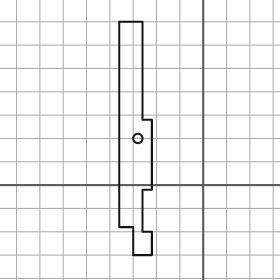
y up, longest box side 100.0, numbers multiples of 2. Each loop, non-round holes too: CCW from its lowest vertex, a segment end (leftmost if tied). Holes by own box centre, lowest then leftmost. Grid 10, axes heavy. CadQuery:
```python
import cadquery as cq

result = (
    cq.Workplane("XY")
    .moveTo(-30.0, -30.0)
    .lineTo(-22.0, -30.0)
    .lineTo(-22.0, -20.0)
    .lineTo(-26.0, -20.0)
    .lineTo(-26.0, -2.0)
    .lineTo(-22.0, -2.0)
    .lineTo(-22.0, 28.0)
    .lineTo(-26.0, 28.0)
    .lineTo(-26.0, 70.0)
    .lineTo(-36.0, 70.0)
    .lineTo(-36.0, -18.0)
    .lineTo(-30.0, -18.0)
    .close()
    .moveTo(-28.0, 20.0)
    .circle(2.0)
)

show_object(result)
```